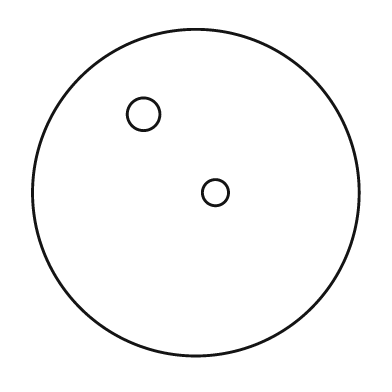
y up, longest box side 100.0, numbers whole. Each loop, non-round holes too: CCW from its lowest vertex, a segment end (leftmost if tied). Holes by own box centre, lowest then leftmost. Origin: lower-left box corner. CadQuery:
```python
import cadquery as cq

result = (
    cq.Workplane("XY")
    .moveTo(50.0, 50.0)
    .circle(50.0)
    .moveTo(56.0, 50.0)
    .circle(4.0)
    .moveTo(34.0, 74.0)
    .circle(5.0)
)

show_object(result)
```